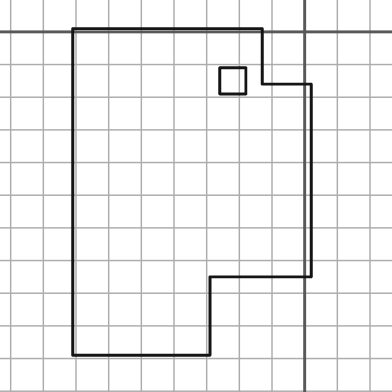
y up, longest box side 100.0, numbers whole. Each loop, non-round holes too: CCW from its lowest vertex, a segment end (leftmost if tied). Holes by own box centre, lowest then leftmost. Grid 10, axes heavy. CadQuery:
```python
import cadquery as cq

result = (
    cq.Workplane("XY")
    .moveTo(-71.0, -99.0)
    .lineTo(-29.0, -99.0)
    .lineTo(-29.0, -75.0)
    .lineTo(2.0, -75.0)
    .lineTo(2.0, -16.0)
    .lineTo(-13.0, -16.0)
    .lineTo(-13.0, 1.0)
    .lineTo(-71.0, 1.0)
    .close()
    .moveTo(-26.0, -19.0)
    .lineTo(-18.0, -19.0)
    .lineTo(-18.0, -11.0)
    .lineTo(-26.0, -11.0)
    .close()
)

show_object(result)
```